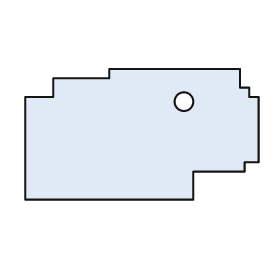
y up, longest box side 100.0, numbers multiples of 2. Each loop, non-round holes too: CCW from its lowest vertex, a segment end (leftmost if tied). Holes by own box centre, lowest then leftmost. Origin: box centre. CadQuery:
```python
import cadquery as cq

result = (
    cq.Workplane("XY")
    .moveTo(-50.0, -28.0)
    .lineTo(22.0, -28.0)
    .lineTo(22.0, -16.0)
    .lineTo(44.0, -16.0)
    .lineTo(44.0, -12.0)
    .lineTo(50.0, -12.0)
    .lineTo(50.0, 16.0)
    .lineTo(46.0, 16.0)
    .lineTo(46.0, 20.0)
    .lineTo(42.0, 20.0)
    .lineTo(42.0, 28.0)
    .lineTo(-14.0, 28.0)
    .lineTo(-14.0, 24.0)
    .lineTo(-38.0, 24.0)
    .lineTo(-38.0, 16.0)
    .lineTo(-50.0, 16.0)
    .close()
    .moveTo(18.0, 14.0)
    .circle(4.0)
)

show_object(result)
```